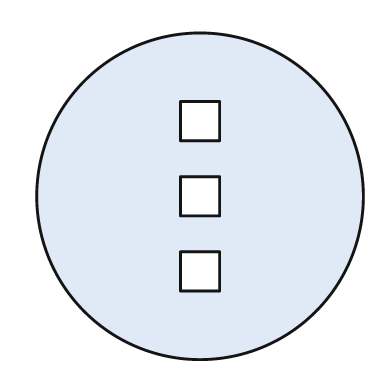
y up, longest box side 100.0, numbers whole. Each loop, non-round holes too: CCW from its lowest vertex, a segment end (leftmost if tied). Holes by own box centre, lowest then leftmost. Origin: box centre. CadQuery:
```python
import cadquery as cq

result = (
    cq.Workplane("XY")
    .moveTo(0.0, 0.0)
    .circle(50.0)
    .moveTo(-6.0, -29.0)
    .lineTo(6.0, -29.0)
    .lineTo(6.0, -17.0)
    .lineTo(-6.0, -17.0)
    .close()
    .moveTo(-6.0, -6.0)
    .lineTo(6.0, -6.0)
    .lineTo(6.0, 6.0)
    .lineTo(-6.0, 6.0)
    .close()
    .moveTo(-6.0, 17.0)
    .lineTo(6.0, 17.0)
    .lineTo(6.0, 29.0)
    .lineTo(-6.0, 29.0)
    .close()
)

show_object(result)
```